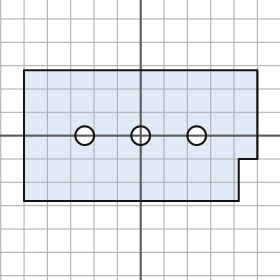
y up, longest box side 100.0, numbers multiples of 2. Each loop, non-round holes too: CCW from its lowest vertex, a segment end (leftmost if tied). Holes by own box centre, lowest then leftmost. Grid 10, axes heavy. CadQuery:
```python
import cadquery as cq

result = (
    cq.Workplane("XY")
    .moveTo(-50.0, -28.0)
    .lineTo(42.0, -28.0)
    .lineTo(42.0, -10.0)
    .lineTo(50.0, -10.0)
    .lineTo(50.0, 28.0)
    .lineTo(-50.0, 28.0)
    .close()
    .moveTo(-24.0, 0.0)
    .circle(4.0)
    .moveTo(0.0, 0.0)
    .circle(4.0)
    .moveTo(24.0, 0.0)
    .circle(4.0)
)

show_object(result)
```